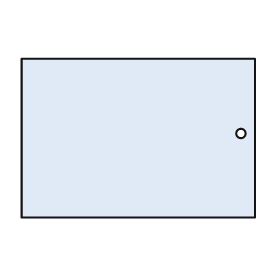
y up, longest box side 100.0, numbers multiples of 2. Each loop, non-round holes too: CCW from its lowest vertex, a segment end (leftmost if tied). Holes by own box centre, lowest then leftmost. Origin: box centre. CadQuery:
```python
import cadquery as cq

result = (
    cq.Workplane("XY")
    .moveTo(-50.0, -34.0)
    .lineTo(50.0, -34.0)
    .lineTo(50.0, 34.0)
    .lineTo(-50.0, 34.0)
    .close()
    .moveTo(44.0, 2.0)
    .circle(2.0)
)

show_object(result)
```